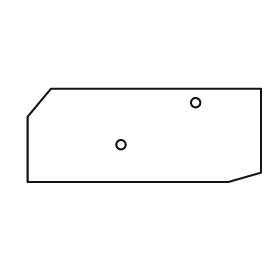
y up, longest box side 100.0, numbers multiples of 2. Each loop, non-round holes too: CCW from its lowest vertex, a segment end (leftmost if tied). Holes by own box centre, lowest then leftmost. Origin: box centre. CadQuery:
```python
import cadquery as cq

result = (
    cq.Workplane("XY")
    .moveTo(-50.0, -20.0)
    .lineTo(36.0, -20.0)
    .lineTo(50.0, -16.0)
    .lineTo(50.0, 20.0)
    .lineTo(-40.0, 20.0)
    .lineTo(-50.0, 8.0)
    .close()
    .moveTo(-10.0, -4.0)
    .circle(2.0)
    .moveTo(22.0, 14.0)
    .circle(2.0)
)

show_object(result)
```